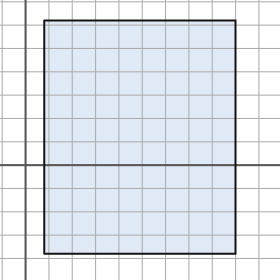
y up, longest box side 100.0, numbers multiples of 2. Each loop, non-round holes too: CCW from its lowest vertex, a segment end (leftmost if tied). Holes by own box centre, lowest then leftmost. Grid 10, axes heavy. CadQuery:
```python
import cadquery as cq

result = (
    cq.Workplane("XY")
    .moveTo(8.0, -38.0)
    .lineTo(90.0, -38.0)
    .lineTo(90.0, 62.0)
    .lineTo(8.0, 62.0)
    .close()
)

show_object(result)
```